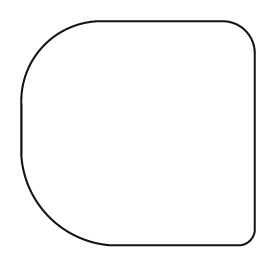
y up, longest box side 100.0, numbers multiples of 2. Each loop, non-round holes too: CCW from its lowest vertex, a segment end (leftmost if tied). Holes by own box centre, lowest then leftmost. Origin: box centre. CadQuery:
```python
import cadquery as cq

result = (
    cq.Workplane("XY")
    .moveTo(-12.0, -48.0)
    .lineTo(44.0, -48.0)
    .threePointArc((48.0, -46.0), (50.0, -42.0))
    .lineTo(50.0, 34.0)
    .threePointArc((46.0, 44.0), (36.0, 48.0))
    .lineTo(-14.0, 48.0)
    .threePointArc((-40.0, 38.0), (-50.0, 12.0))
    .lineTo(-50.0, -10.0)
    .threePointArc((-38.0, -36.0), (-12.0, -48.0))
    .close()
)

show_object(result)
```